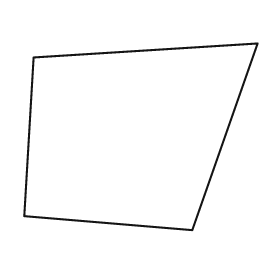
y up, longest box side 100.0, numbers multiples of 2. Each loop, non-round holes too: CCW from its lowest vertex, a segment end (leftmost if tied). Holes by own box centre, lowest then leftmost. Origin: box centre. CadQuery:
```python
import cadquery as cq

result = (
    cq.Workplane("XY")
    .moveTo(22.0, -40.0)
    .lineTo(50.0, 40.0)
    .lineTo(-46.0, 34.0)
    .lineTo(-50.0, -34.0)
    .close()
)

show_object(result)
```